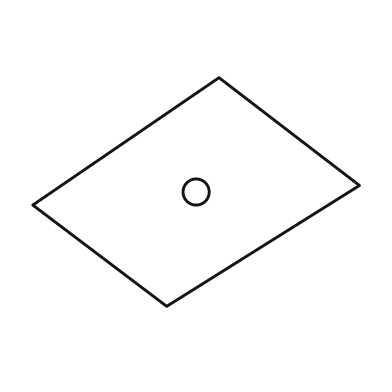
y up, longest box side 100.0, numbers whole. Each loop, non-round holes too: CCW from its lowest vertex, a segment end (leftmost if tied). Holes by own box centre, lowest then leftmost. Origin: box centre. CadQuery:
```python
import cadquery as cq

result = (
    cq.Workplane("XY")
    .moveTo(-9.0, -35.0)
    .lineTo(50.0, 2.0)
    .lineTo(7.0, 35.0)
    .lineTo(-50.0, -4.0)
    .close()
    .moveTo(0.0, 0.0)
    .circle(4.0)
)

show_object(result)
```